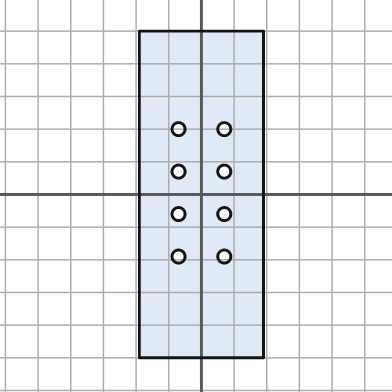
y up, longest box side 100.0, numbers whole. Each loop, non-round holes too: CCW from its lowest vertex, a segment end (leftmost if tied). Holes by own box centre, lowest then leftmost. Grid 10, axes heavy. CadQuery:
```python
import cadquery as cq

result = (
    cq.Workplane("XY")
    .moveTo(-19.0, -50.0)
    .lineTo(19.0, -50.0)
    .lineTo(19.0, 50.0)
    .lineTo(-19.0, 50.0)
    .close()
    .moveTo(-7.0, -19.0)
    .circle(2.0)
    .moveTo(7.0, -19.0)
    .circle(2.0)
    .moveTo(-7.0, -6.0)
    .circle(2.0)
    .moveTo(7.0, -6.0)
    .circle(2.0)
    .moveTo(-7.0, 7.0)
    .circle(2.0)
    .moveTo(7.0, 7.0)
    .circle(2.0)
    .moveTo(-7.0, 20.0)
    .circle(2.0)
    .moveTo(7.0, 20.0)
    .circle(2.0)
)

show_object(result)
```